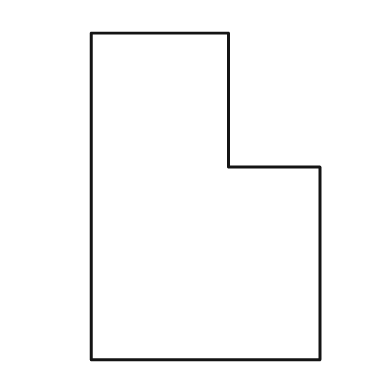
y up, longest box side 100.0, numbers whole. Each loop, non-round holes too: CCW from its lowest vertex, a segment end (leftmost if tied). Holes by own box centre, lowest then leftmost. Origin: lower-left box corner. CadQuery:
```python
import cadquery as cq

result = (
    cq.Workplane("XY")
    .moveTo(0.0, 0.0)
    .lineTo(70.0, 0.0)
    .lineTo(70.0, 59.0)
    .lineTo(42.0, 59.0)
    .lineTo(42.0, 100.0)
    .lineTo(0.0, 100.0)
    .close()
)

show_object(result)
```